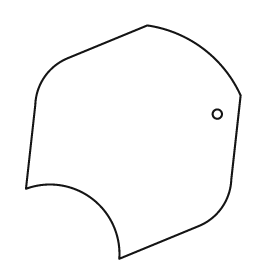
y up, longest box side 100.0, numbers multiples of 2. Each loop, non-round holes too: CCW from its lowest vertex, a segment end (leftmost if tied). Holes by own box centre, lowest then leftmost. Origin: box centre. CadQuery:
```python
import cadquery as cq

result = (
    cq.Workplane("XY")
    .moveTo(-6.0, -50.0)
    .lineTo(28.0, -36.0)
    .threePointArc((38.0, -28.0), (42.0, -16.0))
    .lineTo(46.0, 20.0)
    .threePointArc((30.0, 40.0), (6.0, 50.0))
    .lineTo(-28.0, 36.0)
    .threePointArc((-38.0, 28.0), (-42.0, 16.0))
    .lineTo(-46.0, -20.0)
    .threePointArc((-18.0, -24.0), (-6.0, -50.0))
    .close()
    .moveTo(36.0, 12.0)
    .circle(2.0)
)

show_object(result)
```